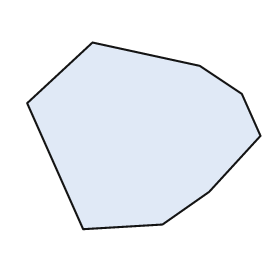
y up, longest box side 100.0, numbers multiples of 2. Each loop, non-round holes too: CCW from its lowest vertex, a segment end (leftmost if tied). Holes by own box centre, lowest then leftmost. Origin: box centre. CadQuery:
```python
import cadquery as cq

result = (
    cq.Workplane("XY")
    .moveTo(-26.0, -40.0)
    .lineTo(8.0, -38.0)
    .lineTo(28.0, -24.0)
    .lineTo(50.0, 0.0)
    .lineTo(42.0, 18.0)
    .lineTo(24.0, 30.0)
    .lineTo(-22.0, 40.0)
    .lineTo(-50.0, 14.0)
    .close()
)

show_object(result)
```